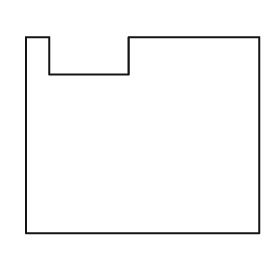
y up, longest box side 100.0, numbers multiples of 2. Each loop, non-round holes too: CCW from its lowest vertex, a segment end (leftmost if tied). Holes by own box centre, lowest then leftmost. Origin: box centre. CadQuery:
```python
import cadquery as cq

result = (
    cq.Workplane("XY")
    .moveTo(-50.0, -42.0)
    .lineTo(50.0, -42.0)
    .lineTo(50.0, 42.0)
    .lineTo(-6.0, 42.0)
    .lineTo(-6.0, 26.0)
    .lineTo(-40.0, 26.0)
    .lineTo(-40.0, 42.0)
    .lineTo(-50.0, 42.0)
    .close()
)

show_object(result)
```